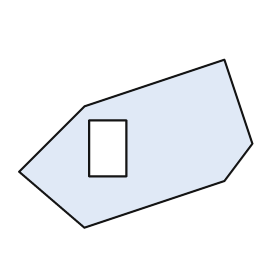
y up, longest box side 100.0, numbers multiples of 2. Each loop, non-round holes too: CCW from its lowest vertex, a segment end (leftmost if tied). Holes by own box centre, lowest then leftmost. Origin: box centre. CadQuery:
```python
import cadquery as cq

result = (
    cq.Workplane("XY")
    .moveTo(-22.0, -36.0)
    .lineTo(38.0, -16.0)
    .lineTo(50.0, 0.0)
    .lineTo(38.0, 36.0)
    .lineTo(-22.0, 16.0)
    .lineTo(-50.0, -12.0)
    .close()
    .moveTo(-20.0, -14.0)
    .lineTo(-4.0, -14.0)
    .lineTo(-4.0, 10.0)
    .lineTo(-20.0, 10.0)
    .close()
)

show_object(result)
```